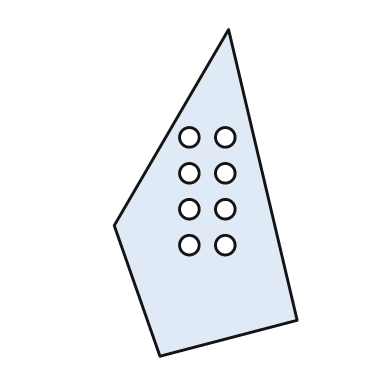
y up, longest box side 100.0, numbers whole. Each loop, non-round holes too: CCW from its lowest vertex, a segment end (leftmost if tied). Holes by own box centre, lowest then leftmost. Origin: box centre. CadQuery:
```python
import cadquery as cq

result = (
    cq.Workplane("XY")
    .moveTo(-14.0, -50.0)
    .lineTo(28.0, -39.0)
    .lineTo(7.0, 50.0)
    .lineTo(-28.0, -10.0)
    .close()
    .moveTo(-5.0, -16.0)
    .circle(3.0)
    .moveTo(6.0, -16.0)
    .circle(3.0)
    .moveTo(-5.0, -5.0)
    .circle(3.0)
    .moveTo(6.0, -5.0)
    .circle(3.0)
    .moveTo(-5.0, 6.0)
    .circle(3.0)
    .moveTo(6.0, 6.0)
    .circle(3.0)
    .moveTo(-5.0, 17.0)
    .circle(3.0)
    .moveTo(6.0, 17.0)
    .circle(3.0)
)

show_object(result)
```